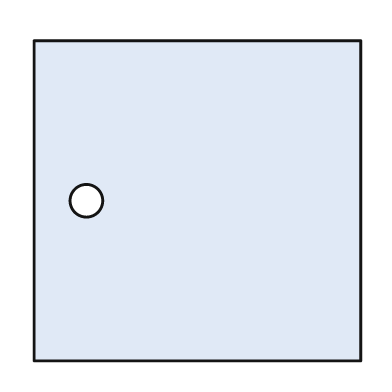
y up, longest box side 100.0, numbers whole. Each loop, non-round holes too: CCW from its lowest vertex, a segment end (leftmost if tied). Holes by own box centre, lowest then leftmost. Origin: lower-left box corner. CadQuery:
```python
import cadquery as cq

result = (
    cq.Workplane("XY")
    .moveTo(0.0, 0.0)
    .lineTo(100.0, 0.0)
    .lineTo(100.0, 98.0)
    .lineTo(0.0, 98.0)
    .close()
    .moveTo(16.0, 49.0)
    .circle(5.0)
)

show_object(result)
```